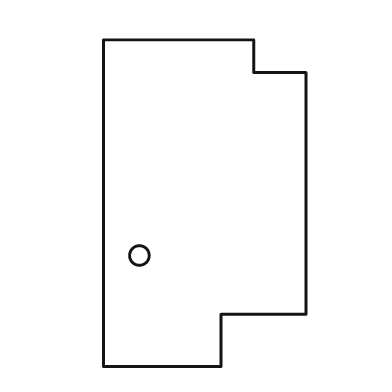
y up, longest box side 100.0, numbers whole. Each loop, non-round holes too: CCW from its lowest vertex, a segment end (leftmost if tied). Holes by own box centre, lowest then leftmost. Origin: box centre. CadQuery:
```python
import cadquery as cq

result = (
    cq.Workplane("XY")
    .moveTo(-31.0, -50.0)
    .lineTo(5.0, -50.0)
    .lineTo(5.0, -34.0)
    .lineTo(31.0, -34.0)
    .lineTo(31.0, 40.0)
    .lineTo(15.0, 40.0)
    .lineTo(15.0, 50.0)
    .lineTo(-31.0, 50.0)
    .close()
    .moveTo(-20.0, -16.0)
    .circle(3.0)
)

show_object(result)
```